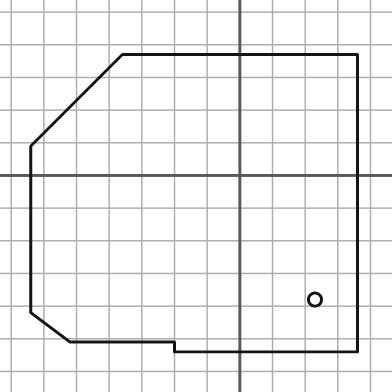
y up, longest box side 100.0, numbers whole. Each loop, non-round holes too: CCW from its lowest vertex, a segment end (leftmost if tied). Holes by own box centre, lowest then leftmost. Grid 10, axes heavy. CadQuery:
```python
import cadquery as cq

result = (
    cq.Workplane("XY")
    .moveTo(-20.0, -54.0)
    .lineTo(36.0, -54.0)
    .lineTo(36.0, 37.0)
    .lineTo(-36.0, 37.0)
    .lineTo(-64.0, 9.0)
    .lineTo(-64.0, -42.0)
    .lineTo(-52.0, -51.0)
    .lineTo(-20.0, -51.0)
    .close()
    .moveTo(23.0, -38.0)
    .circle(2.0)
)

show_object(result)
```